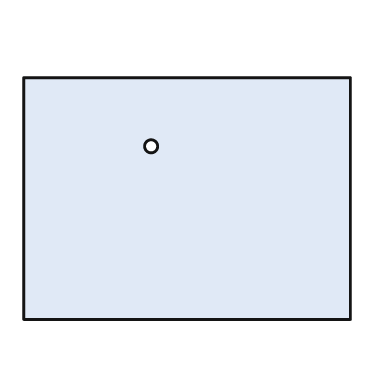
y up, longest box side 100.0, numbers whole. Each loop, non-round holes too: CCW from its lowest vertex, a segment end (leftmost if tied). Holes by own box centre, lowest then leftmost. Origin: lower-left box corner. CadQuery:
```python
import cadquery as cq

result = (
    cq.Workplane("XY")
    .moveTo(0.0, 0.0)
    .lineTo(100.0, 0.0)
    .lineTo(100.0, 74.0)
    .lineTo(0.0, 74.0)
    .close()
    .moveTo(39.0, 53.0)
    .circle(2.0)
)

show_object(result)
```